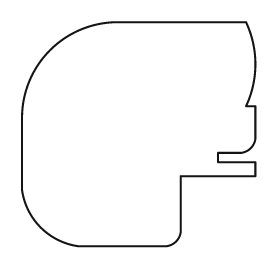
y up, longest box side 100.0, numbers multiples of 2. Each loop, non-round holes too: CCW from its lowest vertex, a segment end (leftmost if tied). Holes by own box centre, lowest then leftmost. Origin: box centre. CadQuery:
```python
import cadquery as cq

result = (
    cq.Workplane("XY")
    .moveTo(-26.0, -48.0)
    .lineTo(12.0, -48.0)
    .threePointArc((16.0, -46.0), (18.0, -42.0))
    .lineTo(18.0, -18.0)
    .lineTo(50.0, -18.0)
    .lineTo(50.0, -12.0)
    .lineTo(34.0, -12.0)
    .lineTo(34.0, -8.0)
    .lineTo(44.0, -8.0)
    .threePointArc((48.0, -6.0), (50.0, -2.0))
    .lineTo(50.0, 12.0)
    .lineTo(46.0, 12.0)
    .threePointArc((50.0, 30.0), (46.0, 48.0))
    .lineTo(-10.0, 48.0)
    .threePointArc((-38.0, 36.0), (-50.0, 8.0))
    .lineTo(-50.0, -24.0)
    .threePointArc((-42.0, -40.0), (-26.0, -48.0))
    .close()
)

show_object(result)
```